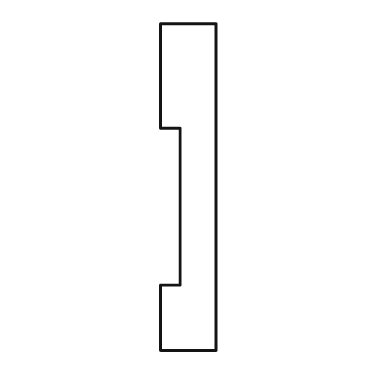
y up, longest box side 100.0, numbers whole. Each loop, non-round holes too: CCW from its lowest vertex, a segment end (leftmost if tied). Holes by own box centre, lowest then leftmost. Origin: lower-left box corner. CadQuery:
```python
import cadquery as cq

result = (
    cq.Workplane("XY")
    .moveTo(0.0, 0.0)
    .lineTo(17.0, 0.0)
    .lineTo(17.0, 100.0)
    .lineTo(0.0, 100.0)
    .lineTo(0.0, 68.0)
    .lineTo(6.0, 68.0)
    .lineTo(6.0, 20.0)
    .lineTo(0.0, 20.0)
    .close()
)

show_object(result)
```